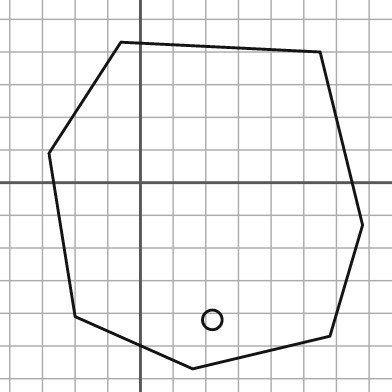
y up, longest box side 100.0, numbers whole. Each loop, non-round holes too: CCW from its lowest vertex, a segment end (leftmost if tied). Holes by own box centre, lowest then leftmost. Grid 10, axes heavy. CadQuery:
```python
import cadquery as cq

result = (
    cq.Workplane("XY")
    .moveTo(16.0, -57.0)
    .lineTo(58.0, -47.0)
    .lineTo(68.0, -13.0)
    .lineTo(55.0, 40.0)
    .lineTo(-6.0, 43.0)
    .lineTo(-28.0, 9.0)
    .lineTo(-20.0, -41.0)
    .close()
    .moveTo(22.0, -42.0)
    .circle(3.0)
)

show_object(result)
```